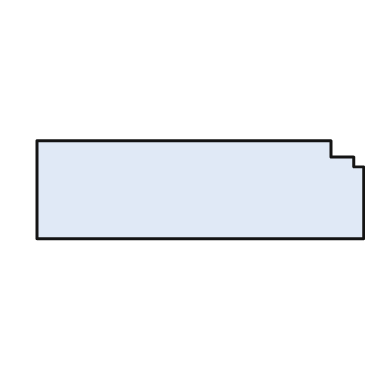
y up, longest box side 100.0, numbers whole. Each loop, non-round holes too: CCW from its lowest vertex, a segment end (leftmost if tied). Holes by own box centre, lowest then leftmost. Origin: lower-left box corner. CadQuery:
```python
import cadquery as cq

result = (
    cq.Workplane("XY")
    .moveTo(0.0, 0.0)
    .lineTo(100.0, 0.0)
    .lineTo(100.0, 22.0)
    .lineTo(97.0, 22.0)
    .lineTo(97.0, 25.0)
    .lineTo(90.0, 25.0)
    .lineTo(90.0, 30.0)
    .lineTo(0.0, 30.0)
    .close()
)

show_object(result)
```